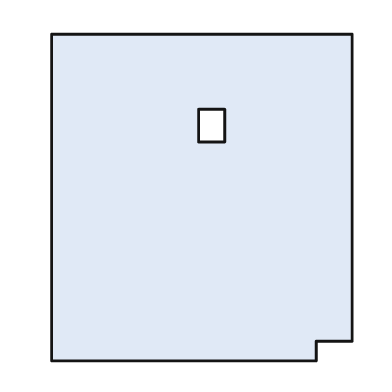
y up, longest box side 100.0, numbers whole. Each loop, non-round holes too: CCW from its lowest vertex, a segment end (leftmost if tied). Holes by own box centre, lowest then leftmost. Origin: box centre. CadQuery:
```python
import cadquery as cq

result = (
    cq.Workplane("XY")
    .moveTo(-46.0, -50.0)
    .lineTo(35.0, -50.0)
    .lineTo(35.0, -44.0)
    .lineTo(46.0, -44.0)
    .lineTo(46.0, 50.0)
    .lineTo(-46.0, 50.0)
    .close()
    .moveTo(-1.0, 17.0)
    .lineTo(7.0, 17.0)
    .lineTo(7.0, 27.0)
    .lineTo(-1.0, 27.0)
    .close()
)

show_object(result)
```